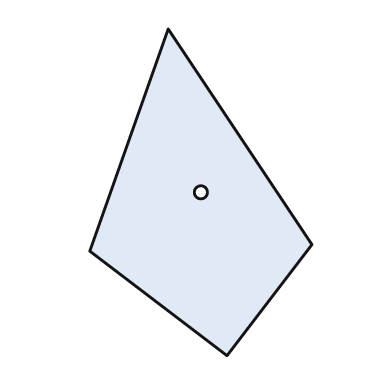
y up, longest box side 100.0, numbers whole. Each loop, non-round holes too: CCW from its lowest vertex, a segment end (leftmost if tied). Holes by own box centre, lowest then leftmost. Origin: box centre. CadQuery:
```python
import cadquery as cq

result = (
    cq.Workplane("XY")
    .moveTo(8.0, -50.0)
    .lineTo(34.0, -16.0)
    .lineTo(-10.0, 50.0)
    .lineTo(-34.0, -18.0)
    .close()
    .moveTo(0.0, 0.0)
    .circle(2.0)
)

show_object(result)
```